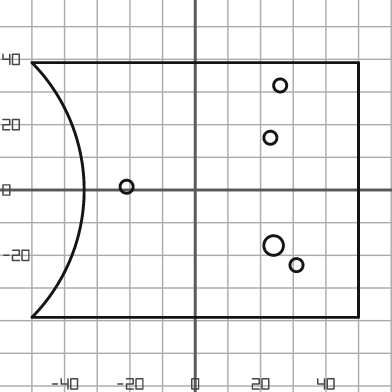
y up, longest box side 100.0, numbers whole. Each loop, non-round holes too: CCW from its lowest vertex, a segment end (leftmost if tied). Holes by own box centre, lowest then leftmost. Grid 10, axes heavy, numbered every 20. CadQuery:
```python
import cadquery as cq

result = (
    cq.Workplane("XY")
    .moveTo(-50.0, -39.0)
    .lineTo(50.0, -39.0)
    .lineTo(50.0, 39.0)
    .lineTo(-50.0, 39.0)
    .threePointArc((-34.0, 0.0), (-50.0, -39.0))
    .close()
    .moveTo(31.0, -23.0)
    .circle(2.0)
    .moveTo(24.0, -17.0)
    .circle(3.0)
    .moveTo(-21.0, 1.0)
    .circle(2.0)
    .moveTo(23.0, 16.0)
    .circle(2.0)
    .moveTo(26.0, 32.0)
    .circle(2.0)
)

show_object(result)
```